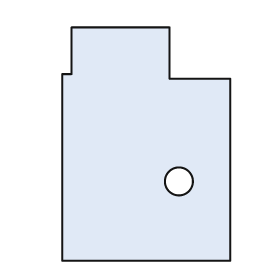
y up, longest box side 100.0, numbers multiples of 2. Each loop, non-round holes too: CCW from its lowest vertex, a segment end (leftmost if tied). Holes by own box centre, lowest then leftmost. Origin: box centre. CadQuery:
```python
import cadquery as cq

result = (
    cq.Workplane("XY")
    .moveTo(-36.0, -50.0)
    .lineTo(36.0, -50.0)
    .lineTo(36.0, 28.0)
    .lineTo(10.0, 28.0)
    .lineTo(10.0, 50.0)
    .lineTo(-32.0, 50.0)
    .lineTo(-32.0, 30.0)
    .lineTo(-36.0, 30.0)
    .close()
    .moveTo(14.0, -16.0)
    .circle(6.0)
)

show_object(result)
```